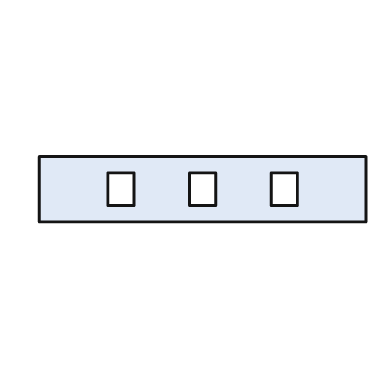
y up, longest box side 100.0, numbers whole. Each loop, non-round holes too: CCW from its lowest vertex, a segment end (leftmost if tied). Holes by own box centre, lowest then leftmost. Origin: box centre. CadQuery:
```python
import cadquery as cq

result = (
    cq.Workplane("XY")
    .moveTo(-50.0, -10.0)
    .lineTo(50.0, -10.0)
    .lineTo(50.0, 10.0)
    .lineTo(-50.0, 10.0)
    .close()
    .moveTo(-29.0, -5.0)
    .lineTo(-21.0, -5.0)
    .lineTo(-21.0, 5.0)
    .lineTo(-29.0, 5.0)
    .close()
    .moveTo(-4.0, -5.0)
    .lineTo(4.0, -5.0)
    .lineTo(4.0, 5.0)
    .lineTo(-4.0, 5.0)
    .close()
    .moveTo(21.0, -5.0)
    .lineTo(29.0, -5.0)
    .lineTo(29.0, 5.0)
    .lineTo(21.0, 5.0)
    .close()
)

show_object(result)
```